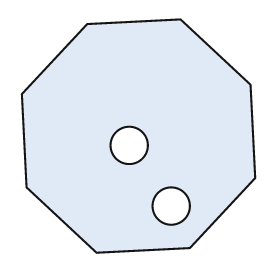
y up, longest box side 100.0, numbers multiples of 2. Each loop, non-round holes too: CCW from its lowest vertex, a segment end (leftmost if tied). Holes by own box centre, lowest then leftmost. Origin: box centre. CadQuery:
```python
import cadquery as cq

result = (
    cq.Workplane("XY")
    .moveTo(-18.0, -50.0)
    .lineTo(22.0, -48.0)
    .lineTo(50.0, -18.0)
    .lineTo(48.0, 22.0)
    .lineTo(18.0, 50.0)
    .lineTo(-22.0, 48.0)
    .lineTo(-50.0, 18.0)
    .lineTo(-48.0, -22.0)
    .close()
    .moveTo(14.0, -30.0)
    .circle(8.0)
    .moveTo(-4.0, -4.0)
    .circle(8.0)
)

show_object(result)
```